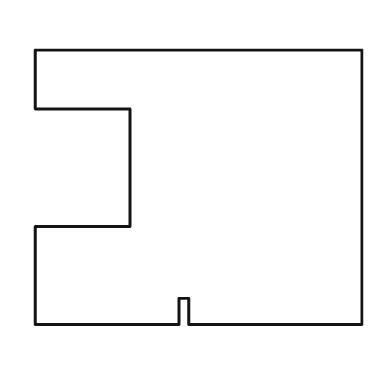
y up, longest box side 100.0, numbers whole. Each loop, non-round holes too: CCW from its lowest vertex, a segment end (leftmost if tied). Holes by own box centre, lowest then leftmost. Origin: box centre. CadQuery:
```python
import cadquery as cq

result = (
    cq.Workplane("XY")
    .moveTo(-50.0, -42.0)
    .lineTo(-6.0, -42.0)
    .lineTo(-6.0, -34.0)
    .lineTo(-3.0, -34.0)
    .lineTo(-3.0, -42.0)
    .lineTo(50.0, -42.0)
    .lineTo(50.0, 42.0)
    .lineTo(-50.0, 42.0)
    .lineTo(-50.0, 24.0)
    .lineTo(-21.0, 24.0)
    .lineTo(-21.0, -12.0)
    .lineTo(-50.0, -12.0)
    .close()
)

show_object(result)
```